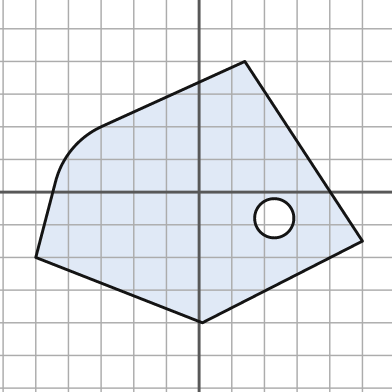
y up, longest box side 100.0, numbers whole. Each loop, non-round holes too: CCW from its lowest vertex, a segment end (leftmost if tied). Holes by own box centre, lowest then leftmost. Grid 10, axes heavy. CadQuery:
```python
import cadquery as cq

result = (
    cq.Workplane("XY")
    .moveTo(1.0, -40.0)
    .lineTo(50.0, -15.0)
    .lineTo(14.0, 40.0)
    .lineTo(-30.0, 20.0)
    .threePointArc((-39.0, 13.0), (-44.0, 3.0))
    .lineTo(-50.0, -20.0)
    .close()
    .moveTo(23.0, -8.0)
    .circle(6.0)
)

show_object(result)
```